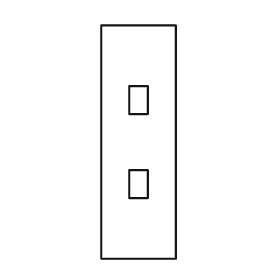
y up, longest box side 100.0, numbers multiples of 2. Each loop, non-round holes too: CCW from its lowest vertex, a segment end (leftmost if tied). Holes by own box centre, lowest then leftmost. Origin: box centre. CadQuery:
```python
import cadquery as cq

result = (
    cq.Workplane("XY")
    .moveTo(-16.0, -50.0)
    .lineTo(16.0, -50.0)
    .lineTo(16.0, 50.0)
    .lineTo(-16.0, 50.0)
    .close()
    .moveTo(-4.0, -24.0)
    .lineTo(4.0, -24.0)
    .lineTo(4.0, -12.0)
    .lineTo(-4.0, -12.0)
    .close()
    .moveTo(-4.0, 12.0)
    .lineTo(4.0, 12.0)
    .lineTo(4.0, 24.0)
    .lineTo(-4.0, 24.0)
    .close()
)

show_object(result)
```